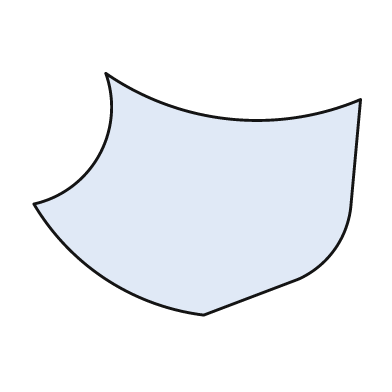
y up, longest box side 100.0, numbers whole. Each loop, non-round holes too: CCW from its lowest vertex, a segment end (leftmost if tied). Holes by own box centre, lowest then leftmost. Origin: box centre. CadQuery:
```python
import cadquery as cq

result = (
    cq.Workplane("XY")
    .moveTo(2.0, -37.0)
    .lineTo(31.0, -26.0)
    .threePointArc((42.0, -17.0), (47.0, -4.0))
    .lineTo(50.0, 29.0)
    .threePointArc((10.0, 23.0), (-28.0, 37.0))
    .threePointArc((-30.0, 12.0), (-50.0, -3.0))
    .threePointArc((-28.0, -26.0), (2.0, -37.0))
    .close()
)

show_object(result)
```